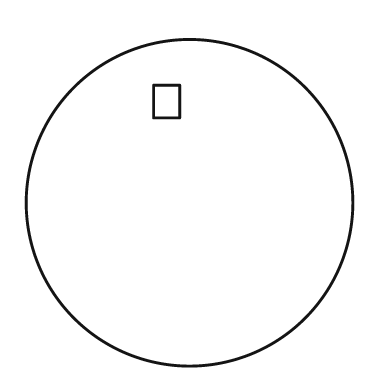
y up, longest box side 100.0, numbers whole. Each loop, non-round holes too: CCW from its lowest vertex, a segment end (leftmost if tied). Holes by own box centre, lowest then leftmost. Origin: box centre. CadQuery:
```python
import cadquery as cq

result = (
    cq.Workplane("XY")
    .moveTo(0.0, 0.0)
    .circle(50.0)
    .moveTo(-11.0, 26.0)
    .lineTo(-3.0, 26.0)
    .lineTo(-3.0, 36.0)
    .lineTo(-11.0, 36.0)
    .close()
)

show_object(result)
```